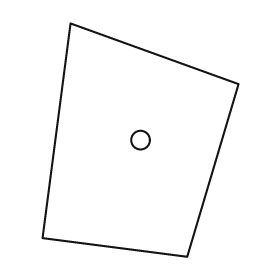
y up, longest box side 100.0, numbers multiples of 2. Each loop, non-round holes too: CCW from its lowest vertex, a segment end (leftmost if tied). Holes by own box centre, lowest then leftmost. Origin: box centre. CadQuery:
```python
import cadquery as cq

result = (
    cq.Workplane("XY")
    .moveTo(20.0, -50.0)
    .lineTo(42.0, 24.0)
    .lineTo(-30.0, 50.0)
    .lineTo(-42.0, -42.0)
    .close()
    .moveTo(0.0, 0.0)
    .circle(4.0)
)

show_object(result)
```